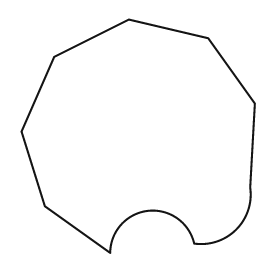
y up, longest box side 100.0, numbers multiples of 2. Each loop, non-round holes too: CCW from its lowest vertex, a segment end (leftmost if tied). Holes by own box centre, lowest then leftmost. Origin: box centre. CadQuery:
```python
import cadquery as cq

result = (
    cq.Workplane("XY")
    .moveTo(-12.0, -50.0)
    .threePointArc((4.0, -32.0), (24.0, -46.0))
    .threePointArc((42.0, -40.0), (48.0, -22.0))
    .lineTo(50.0, 14.0)
    .lineTo(30.0, 42.0)
    .lineTo(-4.0, 50.0)
    .lineTo(-36.0, 34.0)
    .lineTo(-50.0, 2.0)
    .lineTo(-40.0, -30.0)
    .close()
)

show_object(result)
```